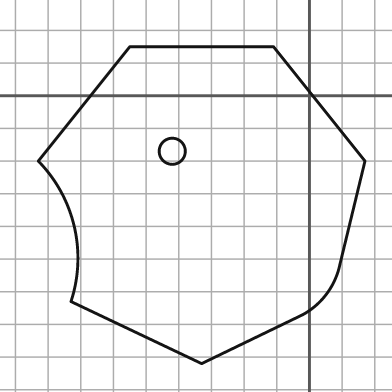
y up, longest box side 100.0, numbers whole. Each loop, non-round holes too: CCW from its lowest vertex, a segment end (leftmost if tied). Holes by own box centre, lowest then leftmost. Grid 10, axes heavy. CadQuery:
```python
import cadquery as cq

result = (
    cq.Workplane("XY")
    .moveTo(-33.0, -82.0)
    .lineTo(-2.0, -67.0)
    .threePointArc((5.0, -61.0), (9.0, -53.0))
    .lineTo(17.0, -20.0)
    .lineTo(-11.0, 15.0)
    .lineTo(-55.0, 15.0)
    .lineTo(-83.0, -20.0)
    .threePointArc((-72.0, -40.0), (-73.0, -63.0))
    .close()
    .moveTo(-42.0, -17.0)
    .circle(4.0)
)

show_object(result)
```